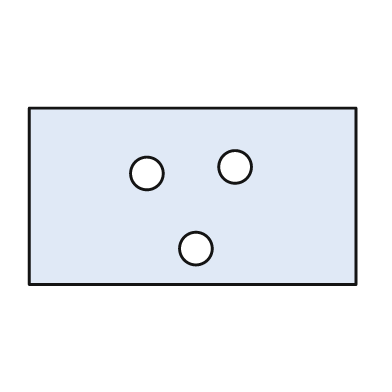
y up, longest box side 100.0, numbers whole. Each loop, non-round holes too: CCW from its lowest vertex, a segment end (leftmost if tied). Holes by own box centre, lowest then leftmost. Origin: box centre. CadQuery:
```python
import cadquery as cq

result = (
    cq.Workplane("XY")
    .moveTo(-50.0, -27.0)
    .lineTo(50.0, -27.0)
    .lineTo(50.0, 27.0)
    .lineTo(-50.0, 27.0)
    .close()
    .moveTo(1.0, -16.0)
    .circle(5.0)
    .moveTo(-14.0, 7.0)
    .circle(5.0)
    .moveTo(13.0, 9.0)
    .circle(5.0)
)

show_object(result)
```